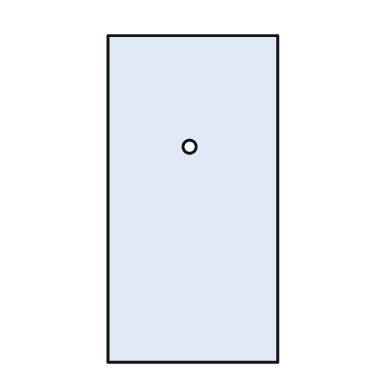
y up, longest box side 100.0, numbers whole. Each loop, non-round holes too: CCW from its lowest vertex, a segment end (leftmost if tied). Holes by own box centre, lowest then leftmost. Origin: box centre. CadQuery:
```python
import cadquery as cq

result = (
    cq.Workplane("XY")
    .moveTo(-26.0, -50.0)
    .lineTo(26.0, -50.0)
    .lineTo(26.0, 50.0)
    .lineTo(-26.0, 50.0)
    .close()
    .moveTo(-1.0, 16.0)
    .circle(2.0)
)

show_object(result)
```